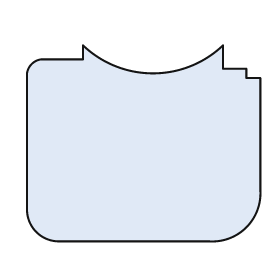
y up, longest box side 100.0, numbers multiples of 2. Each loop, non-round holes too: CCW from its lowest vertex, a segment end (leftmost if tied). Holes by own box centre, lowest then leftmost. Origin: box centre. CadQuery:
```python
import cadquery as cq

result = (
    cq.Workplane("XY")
    .moveTo(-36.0, -42.0)
    .lineTo(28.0, -42.0)
    .threePointArc((44.0, -36.0), (50.0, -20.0))
    .lineTo(50.0, 28.0)
    .lineTo(44.0, 28.0)
    .lineTo(44.0, 32.0)
    .lineTo(34.0, 32.0)
    .lineTo(34.0, 42.0)
    .threePointArc((4.0, 30.0), (-26.0, 42.0))
    .lineTo(-26.0, 36.0)
    .lineTo(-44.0, 36.0)
    .threePointArc((-48.0, 34.0), (-50.0, 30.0))
    .lineTo(-50.0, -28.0)
    .threePointArc((-46.0, -38.0), (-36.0, -42.0))
    .close()
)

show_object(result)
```